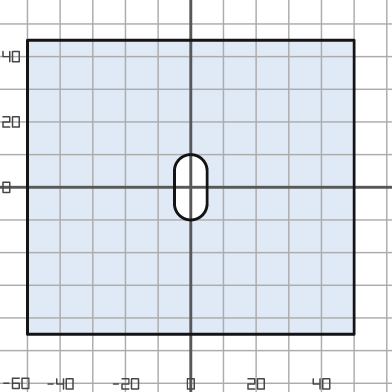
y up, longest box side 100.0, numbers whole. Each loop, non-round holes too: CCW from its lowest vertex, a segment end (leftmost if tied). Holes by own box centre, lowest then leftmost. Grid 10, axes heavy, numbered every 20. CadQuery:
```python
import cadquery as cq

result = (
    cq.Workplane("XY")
    .moveTo(-50.0, -45.0)
    .lineTo(50.0, -45.0)
    .lineTo(50.0, 45.0)
    .lineTo(-50.0, 45.0)
    .close()
    .moveTo(-5.0, -5.0)
    .threePointArc((0.0, -10.0), (5.0, -5.0))
    .lineTo(5.0, 5.0)
    .threePointArc((0.0, 10.0), (-5.0, 5.0))
    .close()
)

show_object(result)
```